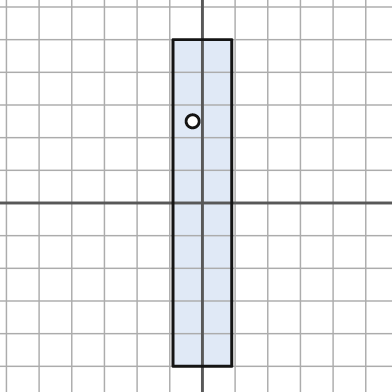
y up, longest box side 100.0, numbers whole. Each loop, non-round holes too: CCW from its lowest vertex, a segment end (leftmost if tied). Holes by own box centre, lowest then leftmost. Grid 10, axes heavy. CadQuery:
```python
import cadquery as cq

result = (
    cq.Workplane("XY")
    .moveTo(-9.0, -50.0)
    .lineTo(9.0, -50.0)
    .lineTo(9.0, 50.0)
    .lineTo(-9.0, 50.0)
    .close()
    .moveTo(-3.0, 25.0)
    .circle(2.0)
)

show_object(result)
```